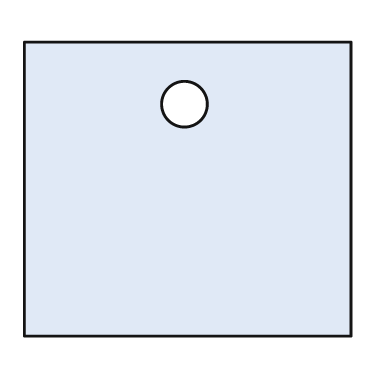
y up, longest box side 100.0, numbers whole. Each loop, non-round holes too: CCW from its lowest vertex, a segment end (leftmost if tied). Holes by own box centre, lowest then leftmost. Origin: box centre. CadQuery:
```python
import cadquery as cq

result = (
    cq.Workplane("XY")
    .moveTo(-50.0, -45.0)
    .lineTo(50.0, -45.0)
    .lineTo(50.0, 45.0)
    .lineTo(-50.0, 45.0)
    .close()
    .moveTo(-1.0, 26.0)
    .circle(7.0)
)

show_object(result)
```